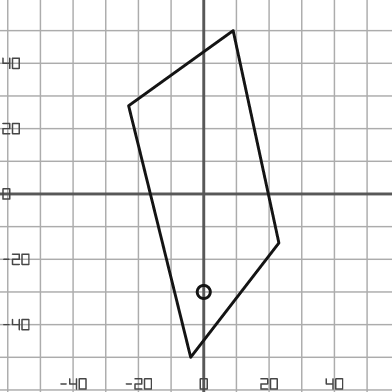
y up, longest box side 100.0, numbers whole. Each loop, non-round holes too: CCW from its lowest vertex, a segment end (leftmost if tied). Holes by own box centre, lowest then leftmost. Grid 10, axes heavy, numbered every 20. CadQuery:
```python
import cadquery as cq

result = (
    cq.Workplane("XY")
    .moveTo(-4.0, -50.0)
    .lineTo(23.0, -15.0)
    .lineTo(9.0, 50.0)
    .lineTo(-23.0, 27.0)
    .close()
    .moveTo(0.0, -30.0)
    .circle(2.0)
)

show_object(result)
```